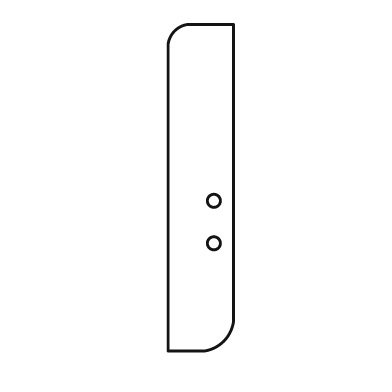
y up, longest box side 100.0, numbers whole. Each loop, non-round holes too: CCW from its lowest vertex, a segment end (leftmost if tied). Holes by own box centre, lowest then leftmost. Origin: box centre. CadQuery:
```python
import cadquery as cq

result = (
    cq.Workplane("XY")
    .moveTo(-10.0, -50.0)
    .lineTo(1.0, -50.0)
    .threePointArc((7.0, -47.0), (10.0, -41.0))
    .lineTo(10.0, 50.0)
    .lineTo(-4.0, 50.0)
    .threePointArc((-8.0, 48.0), (-10.0, 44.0))
    .close()
    .moveTo(4.0, -17.0)
    .circle(2.0)
    .moveTo(4.0, -4.0)
    .circle(2.0)
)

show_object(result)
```